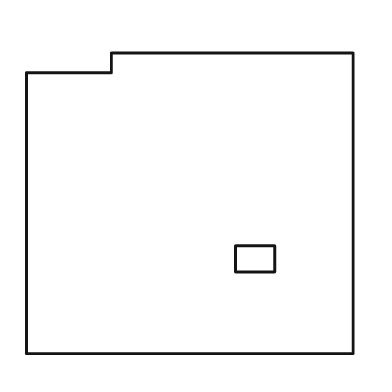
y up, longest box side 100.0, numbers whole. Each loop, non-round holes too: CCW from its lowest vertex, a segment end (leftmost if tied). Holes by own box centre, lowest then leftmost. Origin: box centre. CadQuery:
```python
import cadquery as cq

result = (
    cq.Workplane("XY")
    .moveTo(-50.0, -46.0)
    .lineTo(50.0, -46.0)
    .lineTo(50.0, 46.0)
    .lineTo(-24.0, 46.0)
    .lineTo(-24.0, 40.0)
    .lineTo(-50.0, 40.0)
    .close()
    .moveTo(14.0, -21.0)
    .lineTo(26.0, -21.0)
    .lineTo(26.0, -13.0)
    .lineTo(14.0, -13.0)
    .close()
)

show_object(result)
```